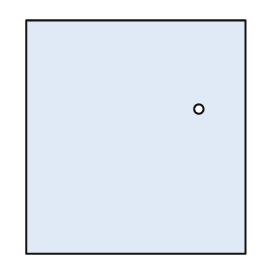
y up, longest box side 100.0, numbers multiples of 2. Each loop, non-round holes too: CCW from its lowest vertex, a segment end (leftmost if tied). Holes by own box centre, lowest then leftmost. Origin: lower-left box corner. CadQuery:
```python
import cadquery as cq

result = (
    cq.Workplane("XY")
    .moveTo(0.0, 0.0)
    .lineTo(94.0, 0.0)
    .lineTo(94.0, 100.0)
    .lineTo(0.0, 100.0)
    .close()
    .moveTo(74.0, 62.0)
    .circle(2.0)
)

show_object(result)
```